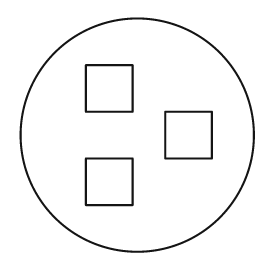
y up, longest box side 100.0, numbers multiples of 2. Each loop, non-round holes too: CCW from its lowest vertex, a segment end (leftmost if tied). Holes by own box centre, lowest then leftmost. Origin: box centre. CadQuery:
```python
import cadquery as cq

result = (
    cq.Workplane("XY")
    .moveTo(0.0, 0.0)
    .circle(50.0)
    .moveTo(-22.0, -30.0)
    .lineTo(-2.0, -30.0)
    .lineTo(-2.0, -10.0)
    .lineTo(-22.0, -10.0)
    .close()
    .moveTo(12.0, -10.0)
    .lineTo(32.0, -10.0)
    .lineTo(32.0, 10.0)
    .lineTo(12.0, 10.0)
    .close()
    .moveTo(-22.0, 10.0)
    .lineTo(-2.0, 10.0)
    .lineTo(-2.0, 30.0)
    .lineTo(-22.0, 30.0)
    .close()
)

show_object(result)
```